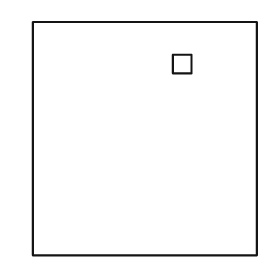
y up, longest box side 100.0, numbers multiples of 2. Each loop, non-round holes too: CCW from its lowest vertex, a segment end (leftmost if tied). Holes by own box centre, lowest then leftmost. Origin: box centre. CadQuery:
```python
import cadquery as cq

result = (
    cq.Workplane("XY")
    .moveTo(-48.0, -50.0)
    .lineTo(48.0, -50.0)
    .lineTo(48.0, 50.0)
    .lineTo(-48.0, 50.0)
    .close()
    .moveTo(12.0, 28.0)
    .lineTo(20.0, 28.0)
    .lineTo(20.0, 36.0)
    .lineTo(12.0, 36.0)
    .close()
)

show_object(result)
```